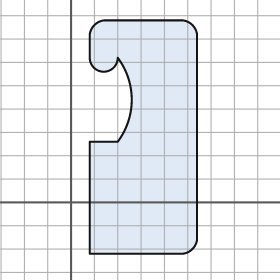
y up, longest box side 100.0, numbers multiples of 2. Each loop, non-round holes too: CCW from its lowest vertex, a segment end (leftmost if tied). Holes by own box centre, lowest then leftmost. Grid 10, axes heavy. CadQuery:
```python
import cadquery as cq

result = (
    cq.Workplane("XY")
    .moveTo(8.0, -22.0)
    .lineTo(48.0, -22.0)
    .threePointArc((52.0, -20.0), (54.0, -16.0))
    .lineTo(54.0, 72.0)
    .threePointArc((52.0, 76.0), (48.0, 78.0))
    .lineTo(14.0, 78.0)
    .threePointArc((10.0, 76.0), (8.0, 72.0))
    .lineTo(8.0, 62.0)
    .threePointArc((14.0, 56.0), (20.0, 62.0))
    .threePointArc((26.0, 44.0), (20.0, 26.0))
    .lineTo(8.0, 26.0)
    .close()
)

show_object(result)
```